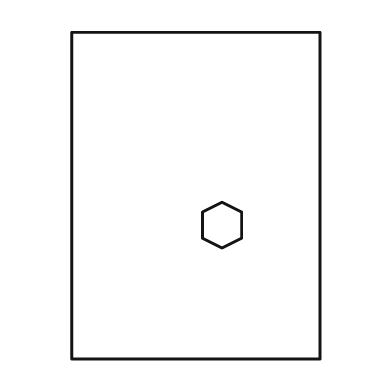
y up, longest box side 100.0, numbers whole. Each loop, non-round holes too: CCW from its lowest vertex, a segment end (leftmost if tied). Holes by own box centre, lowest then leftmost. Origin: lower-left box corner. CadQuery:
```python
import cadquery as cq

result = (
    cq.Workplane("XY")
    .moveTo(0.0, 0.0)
    .lineTo(76.0, 0.0)
    .lineTo(76.0, 100.0)
    .lineTo(0.0, 100.0)
    .close()
    .moveTo(46.0, 34.0)
    .lineTo(52.0, 37.0)
    .lineTo(52.0, 45.0)
    .lineTo(46.0, 48.0)
    .lineTo(40.0, 45.0)
    .lineTo(40.0, 37.0)
    .close()
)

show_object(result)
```